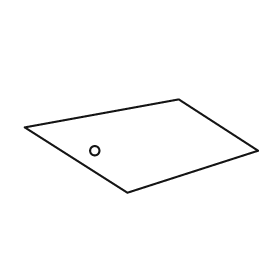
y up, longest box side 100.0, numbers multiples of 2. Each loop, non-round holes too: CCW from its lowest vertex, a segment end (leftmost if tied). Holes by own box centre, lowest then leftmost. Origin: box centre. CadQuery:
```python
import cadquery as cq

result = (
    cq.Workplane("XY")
    .moveTo(-6.0, -20.0)
    .lineTo(50.0, -2.0)
    .lineTo(16.0, 20.0)
    .lineTo(-50.0, 8.0)
    .close()
    .moveTo(-20.0, -2.0)
    .circle(2.0)
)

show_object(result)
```